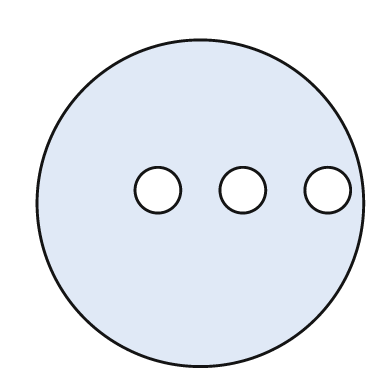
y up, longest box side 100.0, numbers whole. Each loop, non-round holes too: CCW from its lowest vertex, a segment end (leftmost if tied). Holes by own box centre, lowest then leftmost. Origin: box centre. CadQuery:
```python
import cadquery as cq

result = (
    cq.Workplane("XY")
    .moveTo(0.0, 0.0)
    .circle(50.0)
    .moveTo(-13.0, 4.0)
    .circle(7.0)
    .moveTo(13.0, 4.0)
    .circle(7.0)
    .moveTo(39.0, 4.0)
    .circle(7.0)
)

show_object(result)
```